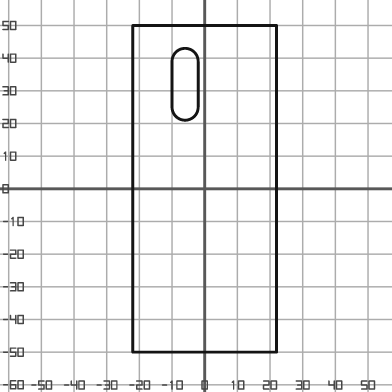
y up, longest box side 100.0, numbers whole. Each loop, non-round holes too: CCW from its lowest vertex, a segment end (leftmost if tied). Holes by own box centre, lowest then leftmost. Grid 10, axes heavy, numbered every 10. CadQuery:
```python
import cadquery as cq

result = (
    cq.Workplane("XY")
    .moveTo(-22.0, -50.0)
    .lineTo(22.0, -50.0)
    .lineTo(22.0, 50.0)
    .lineTo(-22.0, 50.0)
    .close()
    .moveTo(-10.0, 25.0)
    .threePointArc((-6.0, 21.0), (-2.0, 25.0))
    .lineTo(-2.0, 39.0)
    .threePointArc((-6.0, 43.0), (-10.0, 39.0))
    .close()
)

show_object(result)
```